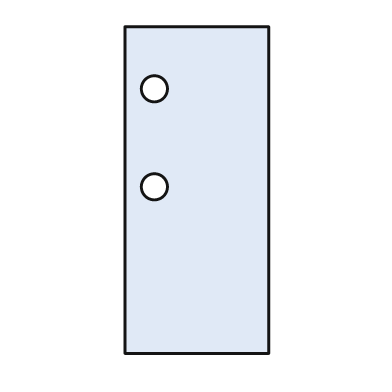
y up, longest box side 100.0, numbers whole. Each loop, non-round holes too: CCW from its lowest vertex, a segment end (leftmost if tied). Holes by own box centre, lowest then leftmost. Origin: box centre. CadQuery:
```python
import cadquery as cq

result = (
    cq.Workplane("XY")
    .moveTo(-22.0, -50.0)
    .lineTo(22.0, -50.0)
    .lineTo(22.0, 50.0)
    .lineTo(-22.0, 50.0)
    .close()
    .moveTo(-13.0, 1.0)
    .circle(4.0)
    .moveTo(-13.0, 31.0)
    .circle(4.0)
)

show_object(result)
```